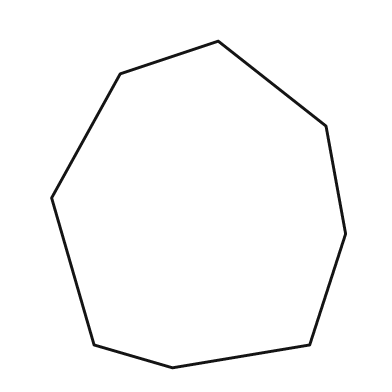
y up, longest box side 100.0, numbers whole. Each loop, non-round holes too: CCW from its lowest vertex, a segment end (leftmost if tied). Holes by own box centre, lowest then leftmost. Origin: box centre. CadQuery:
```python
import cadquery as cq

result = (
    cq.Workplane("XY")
    .moveTo(-8.0, -50.0)
    .lineTo(34.0, -43.0)
    .lineTo(45.0, -9.0)
    .lineTo(39.0, 24.0)
    .lineTo(6.0, 50.0)
    .lineTo(-24.0, 40.0)
    .lineTo(-45.0, 2.0)
    .lineTo(-32.0, -43.0)
    .close()
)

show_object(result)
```